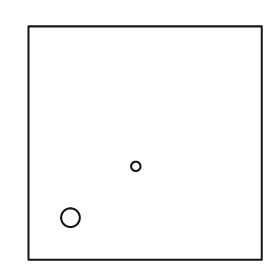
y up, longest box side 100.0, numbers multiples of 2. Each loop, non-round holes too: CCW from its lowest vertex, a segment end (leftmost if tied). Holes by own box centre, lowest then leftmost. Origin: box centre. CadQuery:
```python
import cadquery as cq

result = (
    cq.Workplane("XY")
    .moveTo(-50.0, -50.0)
    .lineTo(50.0, -50.0)
    .lineTo(50.0, 50.0)
    .lineTo(-50.0, 50.0)
    .close()
    .moveTo(-32.0, -32.0)
    .circle(4.0)
    .moveTo(-4.0, -10.0)
    .circle(2.0)
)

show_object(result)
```